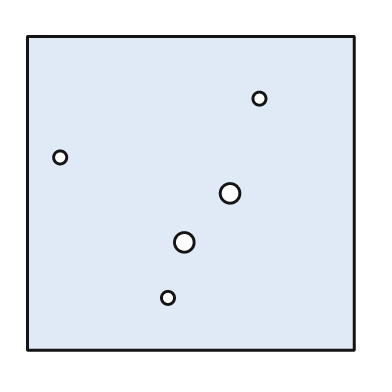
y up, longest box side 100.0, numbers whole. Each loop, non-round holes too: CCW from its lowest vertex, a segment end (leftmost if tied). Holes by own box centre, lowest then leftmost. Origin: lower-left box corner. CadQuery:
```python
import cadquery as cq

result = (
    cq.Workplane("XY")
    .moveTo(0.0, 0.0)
    .lineTo(100.0, 0.0)
    .lineTo(100.0, 96.0)
    .lineTo(0.0, 96.0)
    .close()
    .moveTo(43.0, 16.0)
    .circle(2.0)
    .moveTo(48.0, 33.0)
    .circle(3.0)
    .moveTo(62.0, 48.0)
    .circle(3.0)
    .moveTo(10.0, 59.0)
    .circle(2.0)
    .moveTo(71.0, 77.0)
    .circle(2.0)
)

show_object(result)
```